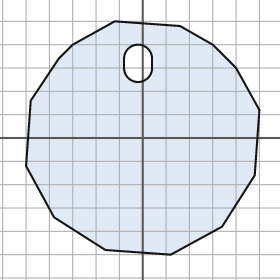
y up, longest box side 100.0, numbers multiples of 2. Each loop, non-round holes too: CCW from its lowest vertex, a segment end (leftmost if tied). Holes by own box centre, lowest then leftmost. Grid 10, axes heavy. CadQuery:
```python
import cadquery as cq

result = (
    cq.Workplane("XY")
    .moveTo(12.0, -50.0)
    .lineTo(34.0, -38.0)
    .lineTo(48.0, -16.0)
    .lineTo(50.0, 12.0)
    .lineTo(40.0, 30.0)
    .lineTo(30.0, 40.0)
    .lineTo(16.0, 48.0)
    .lineTo(-12.0, 50.0)
    .lineTo(-30.0, 40.0)
    .lineTo(-36.0, 34.0)
    .lineTo(-48.0, 16.0)
    .lineTo(-50.0, -12.0)
    .lineTo(-38.0, -34.0)
    .lineTo(-16.0, -48.0)
    .close()
    .moveTo(-8.0, 30.0)
    .threePointArc((-2.0, 24.0), (4.0, 30.0))
    .lineTo(4.0, 34.0)
    .threePointArc((-2.0, 40.0), (-8.0, 34.0))
    .close()
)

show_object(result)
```